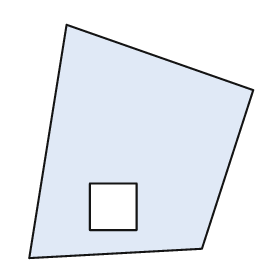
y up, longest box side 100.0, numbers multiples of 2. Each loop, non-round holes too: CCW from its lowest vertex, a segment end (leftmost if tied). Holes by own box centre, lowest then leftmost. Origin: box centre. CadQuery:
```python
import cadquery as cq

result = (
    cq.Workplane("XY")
    .moveTo(-48.0, -50.0)
    .lineTo(26.0, -46.0)
    .lineTo(48.0, 22.0)
    .lineTo(-32.0, 50.0)
    .close()
    .moveTo(-22.0, -38.0)
    .lineTo(-2.0, -38.0)
    .lineTo(-2.0, -18.0)
    .lineTo(-22.0, -18.0)
    .close()
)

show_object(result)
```